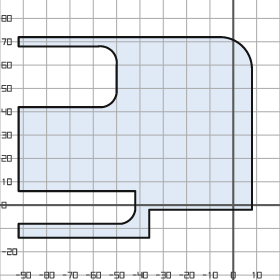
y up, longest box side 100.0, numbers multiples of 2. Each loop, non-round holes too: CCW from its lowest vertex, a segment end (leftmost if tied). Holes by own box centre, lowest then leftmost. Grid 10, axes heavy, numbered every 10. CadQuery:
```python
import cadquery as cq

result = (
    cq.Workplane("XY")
    .moveTo(-92.0, -14.0)
    .lineTo(-36.0, -14.0)
    .lineTo(-36.0, -2.0)
    .lineTo(8.0, -2.0)
    .lineTo(8.0, 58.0)
    .threePointArc((4.0, 68.0), (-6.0, 72.0))
    .lineTo(-92.0, 72.0)
    .lineTo(-92.0, 68.0)
    .lineTo(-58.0, 68.0)
    .threePointArc((-52.0, 66.0), (-50.0, 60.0))
    .lineTo(-50.0, 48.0)
    .threePointArc((-52.0, 44.0), (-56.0, 42.0))
    .lineTo(-92.0, 42.0)
    .lineTo(-92.0, 6.0)
    .lineTo(-42.0, 6.0)
    .lineTo(-42.0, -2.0)
    .threePointArc((-44.0, -6.0), (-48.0, -8.0))
    .lineTo(-92.0, -8.0)
    .close()
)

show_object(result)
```